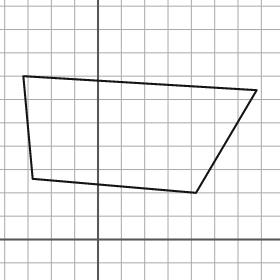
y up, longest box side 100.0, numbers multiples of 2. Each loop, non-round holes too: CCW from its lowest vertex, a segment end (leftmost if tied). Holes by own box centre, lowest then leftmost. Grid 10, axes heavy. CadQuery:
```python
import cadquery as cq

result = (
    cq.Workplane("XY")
    .moveTo(42.0, 20.0)
    .lineTo(68.0, 64.0)
    .lineTo(-32.0, 70.0)
    .lineTo(-28.0, 26.0)
    .close()
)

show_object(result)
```